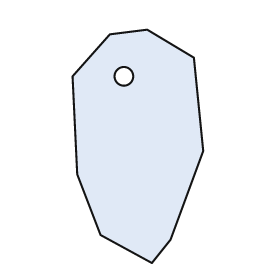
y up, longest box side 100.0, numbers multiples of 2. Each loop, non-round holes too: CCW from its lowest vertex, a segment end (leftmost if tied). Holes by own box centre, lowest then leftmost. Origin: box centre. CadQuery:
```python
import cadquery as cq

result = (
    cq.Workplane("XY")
    .moveTo(6.0, -50.0)
    .lineTo(14.0, -40.0)
    .lineTo(28.0, -2.0)
    .lineTo(24.0, 38.0)
    .lineTo(4.0, 50.0)
    .lineTo(-12.0, 48.0)
    .lineTo(-28.0, 30.0)
    .lineTo(-26.0, -12.0)
    .lineTo(-16.0, -38.0)
    .close()
    .moveTo(-6.0, 30.0)
    .circle(4.0)
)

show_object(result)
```